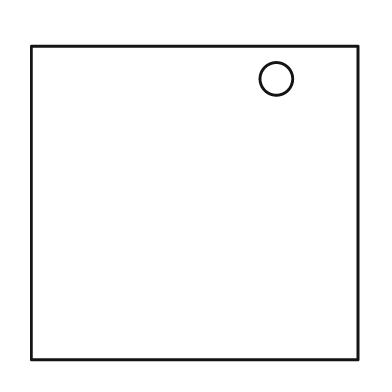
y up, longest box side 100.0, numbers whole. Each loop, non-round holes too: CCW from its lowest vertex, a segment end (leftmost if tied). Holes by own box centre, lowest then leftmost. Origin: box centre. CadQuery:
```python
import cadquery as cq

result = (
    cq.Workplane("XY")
    .moveTo(-50.0, -48.0)
    .lineTo(50.0, -48.0)
    .lineTo(50.0, 48.0)
    .lineTo(-50.0, 48.0)
    .close()
    .moveTo(25.0, 38.0)
    .circle(5.0)
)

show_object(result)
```